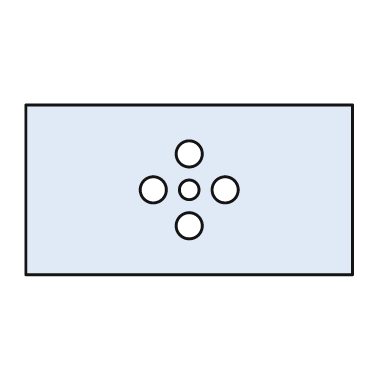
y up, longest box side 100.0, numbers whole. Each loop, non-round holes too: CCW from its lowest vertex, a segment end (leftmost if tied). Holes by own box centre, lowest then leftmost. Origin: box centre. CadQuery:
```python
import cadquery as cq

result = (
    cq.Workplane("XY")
    .moveTo(-50.0, -26.0)
    .lineTo(50.0, -26.0)
    .lineTo(50.0, 26.0)
    .lineTo(-50.0, 26.0)
    .close()
    .moveTo(0.0, -11.0)
    .circle(4.0)
    .moveTo(-11.0, 0.0)
    .circle(4.0)
    .moveTo(0.0, 0.0)
    .circle(3.0)
    .moveTo(11.0, 0.0)
    .circle(4.0)
    .moveTo(0.0, 11.0)
    .circle(4.0)
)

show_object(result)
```